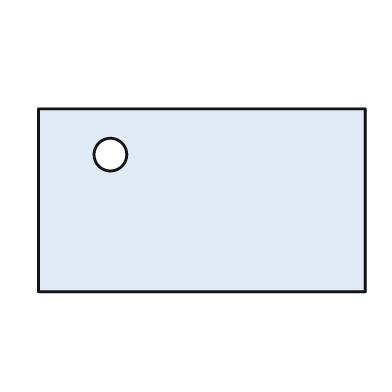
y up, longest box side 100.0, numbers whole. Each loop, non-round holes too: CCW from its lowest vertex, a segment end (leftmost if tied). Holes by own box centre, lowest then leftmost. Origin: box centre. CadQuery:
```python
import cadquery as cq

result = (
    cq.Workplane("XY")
    .moveTo(-50.0, -28.0)
    .lineTo(50.0, -28.0)
    .lineTo(50.0, 28.0)
    .lineTo(-50.0, 28.0)
    .close()
    .moveTo(-28.0, 14.0)
    .circle(5.0)
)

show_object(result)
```